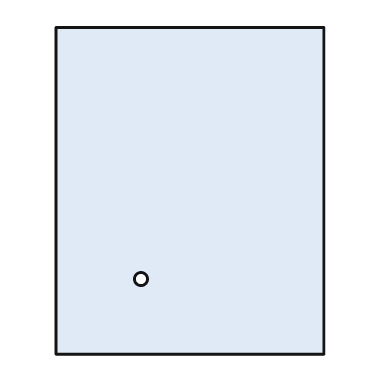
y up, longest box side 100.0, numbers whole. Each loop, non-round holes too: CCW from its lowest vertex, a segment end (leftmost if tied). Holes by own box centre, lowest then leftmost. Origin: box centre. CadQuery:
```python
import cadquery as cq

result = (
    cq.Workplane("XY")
    .moveTo(-41.0, -50.0)
    .lineTo(41.0, -50.0)
    .lineTo(41.0, 50.0)
    .lineTo(-41.0, 50.0)
    .close()
    .moveTo(-15.0, -27.0)
    .circle(2.0)
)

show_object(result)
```